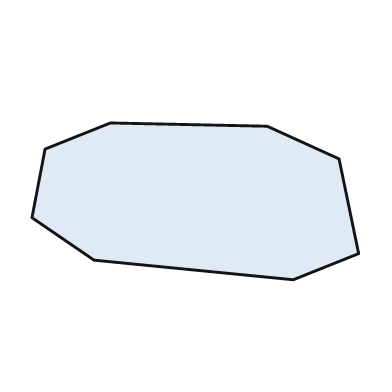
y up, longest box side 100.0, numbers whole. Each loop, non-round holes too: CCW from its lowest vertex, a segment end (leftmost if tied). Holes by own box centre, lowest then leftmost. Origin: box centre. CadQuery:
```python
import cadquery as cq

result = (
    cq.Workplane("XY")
    .moveTo(30.0, -24.0)
    .lineTo(50.0, -16.0)
    .lineTo(44.0, 13.0)
    .lineTo(22.0, 23.0)
    .lineTo(-26.0, 24.0)
    .lineTo(-46.0, 16.0)
    .lineTo(-50.0, -5.0)
    .lineTo(-31.0, -18.0)
    .close()
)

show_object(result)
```